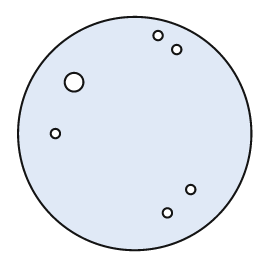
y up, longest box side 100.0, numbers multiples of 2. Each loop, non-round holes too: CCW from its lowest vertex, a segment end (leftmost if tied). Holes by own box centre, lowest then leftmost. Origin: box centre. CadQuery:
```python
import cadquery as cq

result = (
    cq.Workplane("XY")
    .moveTo(0.0, 0.0)
    .circle(50.0)
    .moveTo(14.0, -34.0)
    .circle(2.0)
    .moveTo(24.0, -24.0)
    .circle(2.0)
    .moveTo(-34.0, 0.0)
    .circle(2.0)
    .moveTo(-26.0, 22.0)
    .circle(4.0)
    .moveTo(18.0, 36.0)
    .circle(2.0)
    .moveTo(10.0, 42.0)
    .circle(2.0)
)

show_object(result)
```